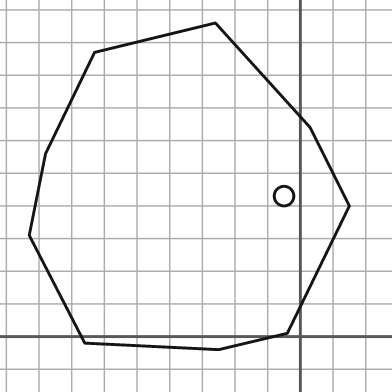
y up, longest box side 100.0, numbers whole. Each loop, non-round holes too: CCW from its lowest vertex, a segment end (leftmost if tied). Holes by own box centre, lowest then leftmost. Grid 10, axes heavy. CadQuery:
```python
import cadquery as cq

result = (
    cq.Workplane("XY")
    .moveTo(-25.0, -4.0)
    .lineTo(-4.0, 1.0)
    .lineTo(15.0, 40.0)
    .lineTo(3.0, 64.0)
    .lineTo(-26.0, 96.0)
    .lineTo(-63.0, 87.0)
    .lineTo(-78.0, 56.0)
    .lineTo(-83.0, 31.0)
    .lineTo(-66.0, -2.0)
    .close()
    .moveTo(-5.0, 43.0)
    .circle(3.0)
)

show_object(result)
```